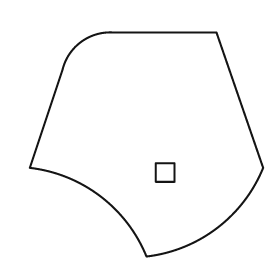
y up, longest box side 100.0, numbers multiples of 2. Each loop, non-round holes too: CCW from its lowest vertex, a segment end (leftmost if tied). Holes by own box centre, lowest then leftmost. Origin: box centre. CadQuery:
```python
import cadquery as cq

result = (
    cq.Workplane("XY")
    .moveTo(0.0, -48.0)
    .threePointArc((30.0, -36.0), (50.0, -10.0))
    .lineTo(30.0, 48.0)
    .lineTo(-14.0, 48.0)
    .threePointArc((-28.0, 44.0), (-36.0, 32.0))
    .lineTo(-50.0, -10.0)
    .threePointArc((-20.0, -22.0), (0.0, -48.0))
    .close()
    .moveTo(4.0, -16.0)
    .lineTo(12.0, -16.0)
    .lineTo(12.0, -8.0)
    .lineTo(4.0, -8.0)
    .close()
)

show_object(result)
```